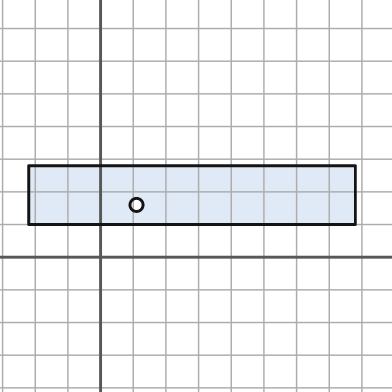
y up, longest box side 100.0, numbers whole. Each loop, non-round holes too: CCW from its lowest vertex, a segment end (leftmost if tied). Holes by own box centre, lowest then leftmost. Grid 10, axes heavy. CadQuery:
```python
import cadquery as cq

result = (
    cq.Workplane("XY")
    .moveTo(-22.0, 10.0)
    .lineTo(78.0, 10.0)
    .lineTo(78.0, 28.0)
    .lineTo(-22.0, 28.0)
    .close()
    .moveTo(11.0, 16.0)
    .circle(2.0)
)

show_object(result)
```